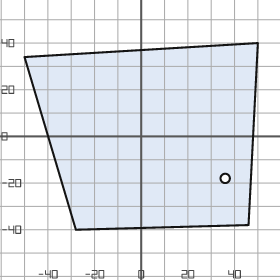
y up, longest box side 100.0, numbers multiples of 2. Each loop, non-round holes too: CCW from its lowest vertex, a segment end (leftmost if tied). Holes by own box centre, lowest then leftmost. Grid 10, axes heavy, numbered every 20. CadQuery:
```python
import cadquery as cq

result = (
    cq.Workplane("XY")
    .moveTo(-28.0, -40.0)
    .lineTo(46.0, -38.0)
    .lineTo(50.0, 40.0)
    .lineTo(-50.0, 34.0)
    .close()
    .moveTo(36.0, -18.0)
    .circle(2.0)
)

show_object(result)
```